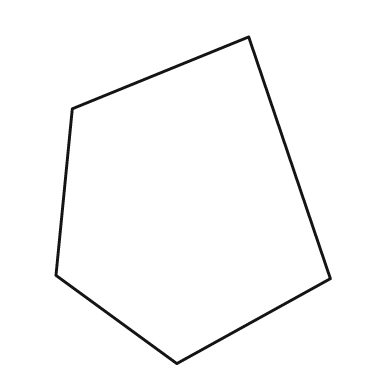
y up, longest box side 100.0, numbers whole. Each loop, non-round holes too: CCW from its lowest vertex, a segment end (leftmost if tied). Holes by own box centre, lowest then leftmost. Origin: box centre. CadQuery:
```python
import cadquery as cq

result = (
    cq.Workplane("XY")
    .moveTo(-5.0, -50.0)
    .lineTo(42.0, -24.0)
    .lineTo(17.0, 50.0)
    .lineTo(-37.0, 28.0)
    .lineTo(-42.0, -23.0)
    .close()
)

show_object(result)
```